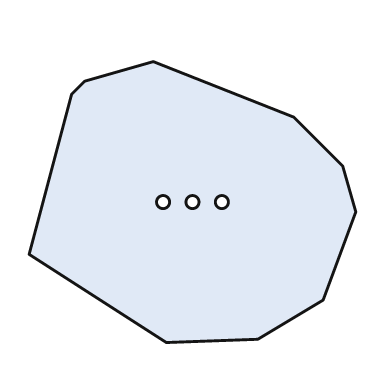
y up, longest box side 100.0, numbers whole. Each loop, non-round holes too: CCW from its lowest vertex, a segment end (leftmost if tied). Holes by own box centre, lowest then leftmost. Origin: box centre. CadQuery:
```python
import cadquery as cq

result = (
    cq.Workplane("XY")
    .moveTo(-8.0, -43.0)
    .lineTo(20.0, -42.0)
    .lineTo(40.0, -30.0)
    .lineTo(50.0, -3.0)
    .lineTo(46.0, 11.0)
    .lineTo(31.0, 26.0)
    .lineTo(-12.0, 43.0)
    .lineTo(-33.0, 37.0)
    .lineTo(-37.0, 33.0)
    .lineTo(-50.0, -16.0)
    .close()
    .moveTo(-9.0, 0.0)
    .circle(2.0)
    .moveTo(0.0, 0.0)
    .circle(2.0)
    .moveTo(9.0, 0.0)
    .circle(2.0)
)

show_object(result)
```